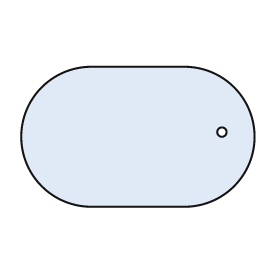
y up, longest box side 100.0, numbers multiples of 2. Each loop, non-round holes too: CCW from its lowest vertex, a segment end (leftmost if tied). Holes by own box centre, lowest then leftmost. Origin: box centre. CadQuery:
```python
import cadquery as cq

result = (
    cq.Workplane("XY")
    .moveTo(-20.0, -30.0)
    .lineTo(20.0, -30.0)
    .threePointArc((50.0, 0.0), (20.0, 30.0))
    .lineTo(-20.0, 30.0)
    .threePointArc((-50.0, 0.0), (-20.0, -30.0))
    .close()
    .moveTo(36.0, 2.0)
    .circle(2.0)
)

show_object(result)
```